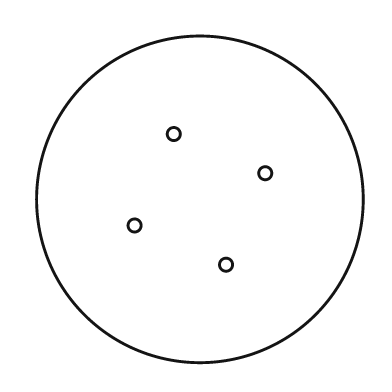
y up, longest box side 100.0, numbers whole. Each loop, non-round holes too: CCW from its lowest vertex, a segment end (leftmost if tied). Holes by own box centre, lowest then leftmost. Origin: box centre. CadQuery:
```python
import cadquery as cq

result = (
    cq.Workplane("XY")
    .moveTo(0.0, 0.0)
    .circle(50.0)
    .moveTo(8.0, -20.0)
    .circle(2.0)
    .moveTo(-20.0, -8.0)
    .circle(2.0)
    .moveTo(20.0, 8.0)
    .circle(2.0)
    .moveTo(-8.0, 20.0)
    .circle(2.0)
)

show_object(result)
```